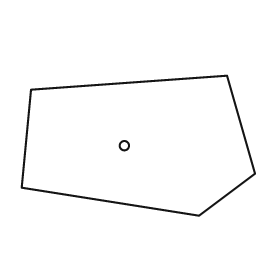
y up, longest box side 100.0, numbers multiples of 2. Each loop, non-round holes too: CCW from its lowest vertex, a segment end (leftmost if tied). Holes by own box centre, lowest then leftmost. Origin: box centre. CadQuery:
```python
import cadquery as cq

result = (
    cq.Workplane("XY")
    .moveTo(26.0, -30.0)
    .lineTo(50.0, -12.0)
    .lineTo(38.0, 30.0)
    .lineTo(-46.0, 24.0)
    .lineTo(-50.0, -18.0)
    .close()
    .moveTo(-6.0, 0.0)
    .circle(2.0)
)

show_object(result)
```